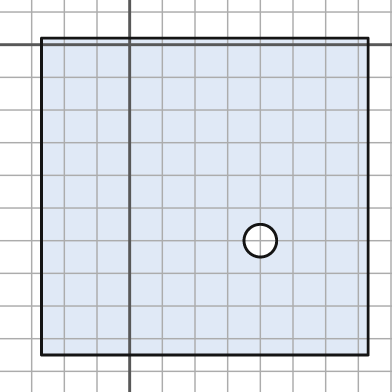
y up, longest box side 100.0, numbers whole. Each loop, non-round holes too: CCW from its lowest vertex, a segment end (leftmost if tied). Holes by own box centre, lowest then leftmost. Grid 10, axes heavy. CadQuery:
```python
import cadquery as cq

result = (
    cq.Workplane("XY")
    .moveTo(-27.0, -95.0)
    .lineTo(73.0, -95.0)
    .lineTo(73.0, 2.0)
    .lineTo(-27.0, 2.0)
    .close()
    .moveTo(40.0, -60.0)
    .circle(5.0)
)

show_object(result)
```